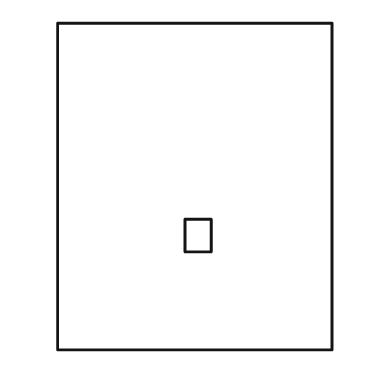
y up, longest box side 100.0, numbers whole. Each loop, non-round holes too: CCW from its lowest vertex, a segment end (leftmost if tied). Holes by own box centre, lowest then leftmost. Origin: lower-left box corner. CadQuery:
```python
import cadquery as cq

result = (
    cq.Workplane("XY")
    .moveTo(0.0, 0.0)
    .lineTo(84.0, 0.0)
    .lineTo(84.0, 100.0)
    .lineTo(0.0, 100.0)
    .close()
    .moveTo(39.0, 30.0)
    .lineTo(47.0, 30.0)
    .lineTo(47.0, 40.0)
    .lineTo(39.0, 40.0)
    .close()
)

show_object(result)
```